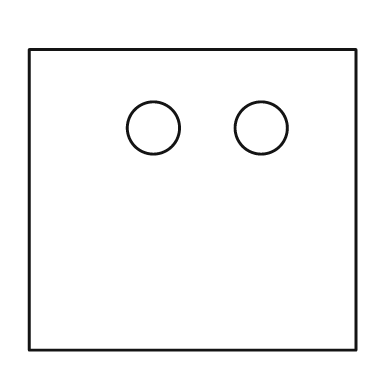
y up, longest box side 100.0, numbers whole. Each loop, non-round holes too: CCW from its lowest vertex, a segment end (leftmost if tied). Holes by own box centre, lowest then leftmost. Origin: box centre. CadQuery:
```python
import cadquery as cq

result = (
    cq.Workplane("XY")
    .moveTo(-50.0, -46.0)
    .lineTo(50.0, -46.0)
    .lineTo(50.0, 46.0)
    .lineTo(-50.0, 46.0)
    .close()
    .moveTo(-12.0, 22.0)
    .circle(8.0)
    .moveTo(21.0, 22.0)
    .circle(8.0)
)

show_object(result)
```